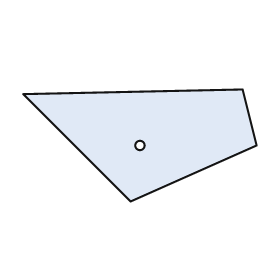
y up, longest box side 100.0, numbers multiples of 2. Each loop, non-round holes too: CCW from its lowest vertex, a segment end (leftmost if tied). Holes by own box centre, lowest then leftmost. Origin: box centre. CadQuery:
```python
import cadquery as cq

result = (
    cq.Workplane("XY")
    .moveTo(-4.0, -24.0)
    .lineTo(50.0, 0.0)
    .lineTo(44.0, 24.0)
    .lineTo(-50.0, 22.0)
    .close()
    .moveTo(0.0, 0.0)
    .circle(2.0)
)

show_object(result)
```